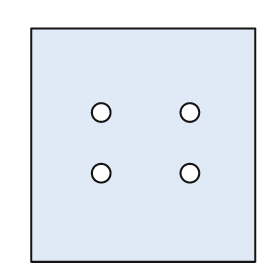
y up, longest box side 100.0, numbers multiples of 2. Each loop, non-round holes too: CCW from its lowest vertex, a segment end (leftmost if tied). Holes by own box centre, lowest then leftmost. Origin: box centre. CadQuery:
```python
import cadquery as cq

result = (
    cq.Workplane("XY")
    .moveTo(-48.0, -50.0)
    .lineTo(48.0, -50.0)
    .lineTo(48.0, 50.0)
    .lineTo(-48.0, 50.0)
    .close()
    .moveTo(-18.0, -12.0)
    .circle(4.0)
    .moveTo(20.0, -12.0)
    .circle(4.0)
    .moveTo(-18.0, 14.0)
    .circle(4.0)
    .moveTo(20.0, 14.0)
    .circle(4.0)
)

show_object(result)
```